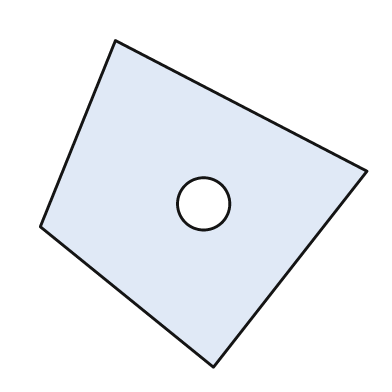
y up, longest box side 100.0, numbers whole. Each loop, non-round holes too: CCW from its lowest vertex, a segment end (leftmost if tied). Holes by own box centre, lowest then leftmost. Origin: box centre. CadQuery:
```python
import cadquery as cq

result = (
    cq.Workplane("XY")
    .moveTo(3.0, -50.0)
    .lineTo(50.0, 10.0)
    .lineTo(-27.0, 50.0)
    .lineTo(-50.0, -7.0)
    .close()
    .moveTo(0.0, 0.0)
    .circle(8.0)
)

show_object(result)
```